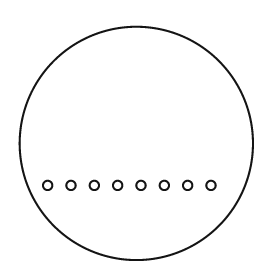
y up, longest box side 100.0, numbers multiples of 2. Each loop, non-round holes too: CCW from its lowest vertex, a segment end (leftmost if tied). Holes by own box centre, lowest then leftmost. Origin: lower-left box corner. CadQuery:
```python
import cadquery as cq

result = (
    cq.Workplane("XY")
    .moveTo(50.0, 50.0)
    .circle(50.0)
    .moveTo(12.0, 32.0)
    .circle(2.0)
    .moveTo(22.0, 32.0)
    .circle(2.0)
    .moveTo(32.0, 32.0)
    .circle(2.0)
    .moveTo(42.0, 32.0)
    .circle(2.0)
    .moveTo(52.0, 32.0)
    .circle(2.0)
    .moveTo(62.0, 32.0)
    .circle(2.0)
    .moveTo(72.0, 32.0)
    .circle(2.0)
    .moveTo(82.0, 32.0)
    .circle(2.0)
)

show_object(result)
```